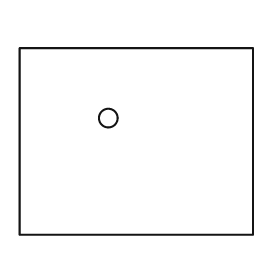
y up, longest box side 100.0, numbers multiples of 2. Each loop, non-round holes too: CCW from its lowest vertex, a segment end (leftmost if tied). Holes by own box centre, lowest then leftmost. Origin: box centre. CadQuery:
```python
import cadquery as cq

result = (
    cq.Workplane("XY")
    .moveTo(-50.0, -40.0)
    .lineTo(50.0, -40.0)
    .lineTo(50.0, 40.0)
    .lineTo(-50.0, 40.0)
    .close()
    .moveTo(-12.0, 10.0)
    .circle(4.0)
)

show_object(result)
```